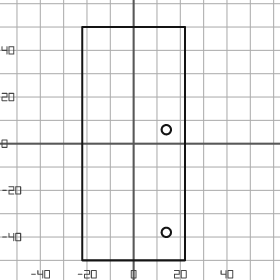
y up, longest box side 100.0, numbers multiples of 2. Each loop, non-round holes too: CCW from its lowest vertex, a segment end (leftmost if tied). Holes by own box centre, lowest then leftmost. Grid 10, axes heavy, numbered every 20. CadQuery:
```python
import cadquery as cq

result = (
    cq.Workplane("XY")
    .moveTo(-22.0, -50.0)
    .lineTo(22.0, -50.0)
    .lineTo(22.0, 50.0)
    .lineTo(-22.0, 50.0)
    .close()
    .moveTo(14.0, -38.0)
    .circle(2.0)
    .moveTo(14.0, 6.0)
    .circle(2.0)
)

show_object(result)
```